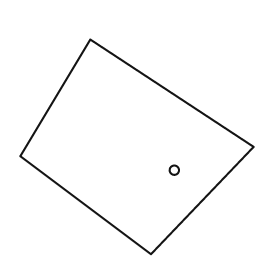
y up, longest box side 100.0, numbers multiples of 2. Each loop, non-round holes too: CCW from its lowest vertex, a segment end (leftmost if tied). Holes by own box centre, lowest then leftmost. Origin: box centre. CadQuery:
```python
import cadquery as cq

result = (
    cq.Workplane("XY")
    .moveTo(6.0, -46.0)
    .lineTo(50.0, 0.0)
    .lineTo(-20.0, 46.0)
    .lineTo(-50.0, -4.0)
    .close()
    .moveTo(16.0, -10.0)
    .circle(2.0)
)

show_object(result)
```